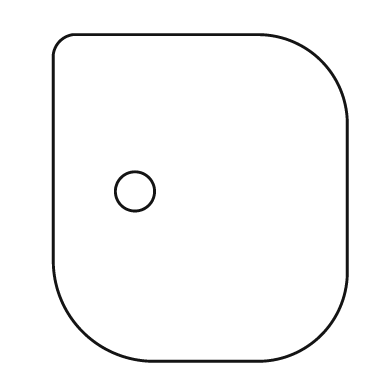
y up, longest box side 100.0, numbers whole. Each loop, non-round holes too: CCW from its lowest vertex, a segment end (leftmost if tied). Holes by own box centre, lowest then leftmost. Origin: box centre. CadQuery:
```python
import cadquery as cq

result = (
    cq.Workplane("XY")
    .moveTo(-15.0, -50.0)
    .lineTo(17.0, -50.0)
    .threePointArc((37.0, -42.0), (45.0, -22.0))
    .lineTo(45.0, 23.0)
    .threePointArc((37.0, 42.0), (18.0, 50.0))
    .lineTo(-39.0, 50.0)
    .threePointArc((-43.0, 48.0), (-45.0, 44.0))
    .lineTo(-45.0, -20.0)
    .threePointArc((-36.0, -41.0), (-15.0, -50.0))
    .close()
    .moveTo(-20.0, 2.0)
    .circle(6.0)
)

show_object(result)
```